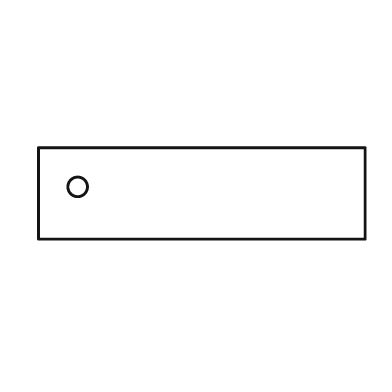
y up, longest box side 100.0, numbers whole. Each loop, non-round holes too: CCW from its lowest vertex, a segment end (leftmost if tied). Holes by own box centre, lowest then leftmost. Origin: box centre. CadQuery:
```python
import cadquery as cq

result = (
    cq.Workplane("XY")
    .moveTo(-50.0, -14.0)
    .lineTo(50.0, -14.0)
    .lineTo(50.0, 14.0)
    .lineTo(-50.0, 14.0)
    .close()
    .moveTo(-38.0, 2.0)
    .circle(3.0)
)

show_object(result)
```